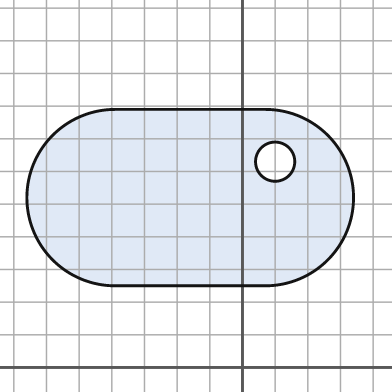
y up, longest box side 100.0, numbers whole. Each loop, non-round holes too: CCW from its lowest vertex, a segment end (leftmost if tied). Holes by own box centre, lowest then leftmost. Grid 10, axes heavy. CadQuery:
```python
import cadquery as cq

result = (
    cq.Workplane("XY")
    .moveTo(-39.0, 25.0)
    .lineTo(7.0, 25.0)
    .threePointArc((34.0, 52.0), (7.0, 79.0))
    .lineTo(-39.0, 79.0)
    .threePointArc((-66.0, 52.0), (-39.0, 25.0))
    .close()
    .moveTo(10.0, 63.0)
    .circle(6.0)
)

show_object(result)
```